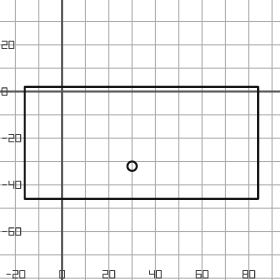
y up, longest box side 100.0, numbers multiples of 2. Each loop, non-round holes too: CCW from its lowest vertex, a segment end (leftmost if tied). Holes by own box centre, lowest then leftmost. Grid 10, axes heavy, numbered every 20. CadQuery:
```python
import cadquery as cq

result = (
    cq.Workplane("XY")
    .moveTo(-16.0, -46.0)
    .lineTo(84.0, -46.0)
    .lineTo(84.0, 2.0)
    .lineTo(-16.0, 2.0)
    .close()
    .moveTo(30.0, -32.0)
    .circle(2.0)
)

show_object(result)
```